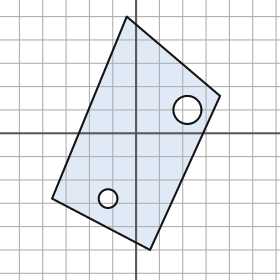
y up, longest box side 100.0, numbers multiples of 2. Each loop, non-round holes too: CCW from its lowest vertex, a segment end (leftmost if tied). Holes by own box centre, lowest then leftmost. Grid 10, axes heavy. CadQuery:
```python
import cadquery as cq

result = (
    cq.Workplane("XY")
    .moveTo(6.0, -50.0)
    .lineTo(36.0, 16.0)
    .lineTo(-4.0, 50.0)
    .lineTo(-36.0, -28.0)
    .close()
    .moveTo(-12.0, -28.0)
    .circle(4.0)
    .moveTo(22.0, 10.0)
    .circle(6.0)
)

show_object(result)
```